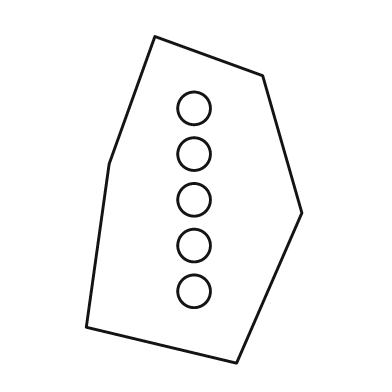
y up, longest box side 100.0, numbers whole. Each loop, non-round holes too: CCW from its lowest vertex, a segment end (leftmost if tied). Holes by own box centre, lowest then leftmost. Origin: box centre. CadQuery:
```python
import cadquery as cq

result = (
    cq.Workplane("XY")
    .moveTo(13.0, -50.0)
    .lineTo(33.0, -4.0)
    .lineTo(21.0, 38.0)
    .lineTo(-12.0, 50.0)
    .lineTo(-26.0, 11.0)
    .lineTo(-33.0, -39.0)
    .close()
    .moveTo(0.0, -28.0)
    .circle(5.0)
    .moveTo(0.0, -14.0)
    .circle(5.0)
    .moveTo(0.0, 0.0)
    .circle(5.0)
    .moveTo(0.0, 14.0)
    .circle(5.0)
    .moveTo(0.0, 28.0)
    .circle(5.0)
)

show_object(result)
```